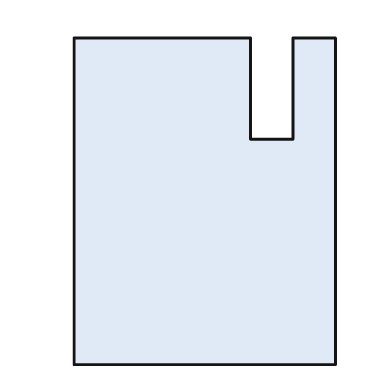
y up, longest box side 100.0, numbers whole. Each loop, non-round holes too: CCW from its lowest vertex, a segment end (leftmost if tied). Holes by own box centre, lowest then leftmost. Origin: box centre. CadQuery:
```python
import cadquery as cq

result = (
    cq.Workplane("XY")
    .moveTo(-40.0, -50.0)
    .lineTo(40.0, -50.0)
    .lineTo(40.0, 50.0)
    .lineTo(27.0, 50.0)
    .lineTo(27.0, 19.0)
    .lineTo(14.0, 19.0)
    .lineTo(14.0, 50.0)
    .lineTo(-40.0, 50.0)
    .close()
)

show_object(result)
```